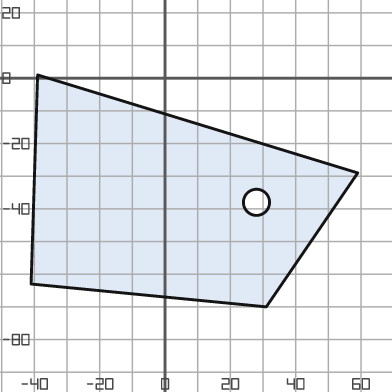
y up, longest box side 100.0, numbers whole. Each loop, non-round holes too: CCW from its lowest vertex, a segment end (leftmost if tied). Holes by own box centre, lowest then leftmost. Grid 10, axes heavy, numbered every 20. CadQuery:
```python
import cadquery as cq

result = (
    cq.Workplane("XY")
    .moveTo(31.0, -70.0)
    .lineTo(59.0, -29.0)
    .lineTo(-39.0, 1.0)
    .lineTo(-41.0, -63.0)
    .close()
    .moveTo(28.0, -38.0)
    .circle(4.0)
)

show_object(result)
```